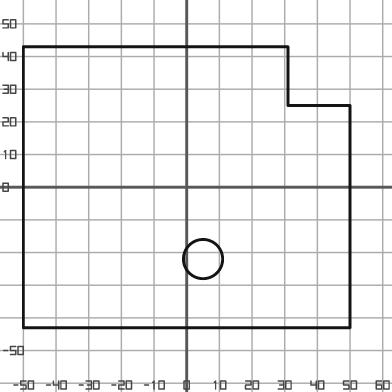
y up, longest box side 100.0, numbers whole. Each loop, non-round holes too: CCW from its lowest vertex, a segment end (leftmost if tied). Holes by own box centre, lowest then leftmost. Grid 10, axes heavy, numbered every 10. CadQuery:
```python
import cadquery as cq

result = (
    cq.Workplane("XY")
    .moveTo(-50.0, -43.0)
    .lineTo(50.0, -43.0)
    .lineTo(50.0, 25.0)
    .lineTo(31.0, 25.0)
    .lineTo(31.0, 43.0)
    .lineTo(-50.0, 43.0)
    .close()
    .moveTo(5.0, -22.0)
    .circle(6.0)
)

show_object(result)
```